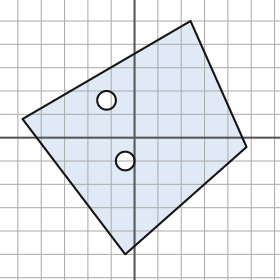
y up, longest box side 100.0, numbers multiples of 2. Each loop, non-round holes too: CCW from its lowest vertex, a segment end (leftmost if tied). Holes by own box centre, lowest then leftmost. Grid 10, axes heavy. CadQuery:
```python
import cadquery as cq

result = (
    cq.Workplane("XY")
    .moveTo(-4.0, -50.0)
    .lineTo(48.0, -4.0)
    .lineTo(24.0, 50.0)
    .lineTo(-48.0, 8.0)
    .close()
    .moveTo(-4.0, -10.0)
    .circle(4.0)
    .moveTo(-12.0, 16.0)
    .circle(4.0)
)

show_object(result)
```